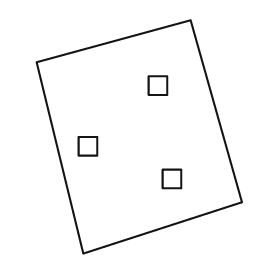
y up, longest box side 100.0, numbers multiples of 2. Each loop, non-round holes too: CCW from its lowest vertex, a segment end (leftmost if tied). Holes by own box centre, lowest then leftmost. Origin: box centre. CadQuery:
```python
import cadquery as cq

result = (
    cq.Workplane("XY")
    .moveTo(-24.0, -50.0)
    .lineTo(44.0, -28.0)
    .lineTo(22.0, 50.0)
    .lineTo(-44.0, 32.0)
    .close()
    .moveTo(10.0, -22.0)
    .lineTo(18.0, -22.0)
    .lineTo(18.0, -14.0)
    .lineTo(10.0, -14.0)
    .close()
    .moveTo(-26.0, -8.0)
    .lineTo(-18.0, -8.0)
    .lineTo(-18.0, 0.0)
    .lineTo(-26.0, 0.0)
    .close()
    .moveTo(4.0, 18.0)
    .lineTo(12.0, 18.0)
    .lineTo(12.0, 26.0)
    .lineTo(4.0, 26.0)
    .close()
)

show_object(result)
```